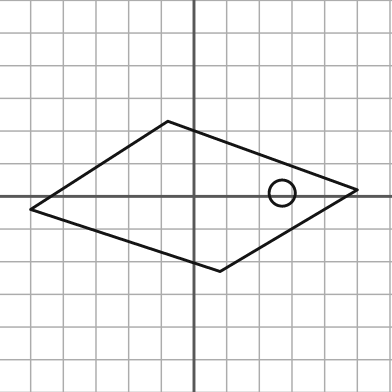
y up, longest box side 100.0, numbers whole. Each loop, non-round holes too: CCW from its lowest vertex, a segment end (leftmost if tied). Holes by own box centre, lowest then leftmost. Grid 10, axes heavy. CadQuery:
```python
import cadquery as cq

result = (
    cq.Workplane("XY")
    .moveTo(8.0, -23.0)
    .lineTo(50.0, 2.0)
    .lineTo(-8.0, 23.0)
    .lineTo(-50.0, -4.0)
    .close()
    .moveTo(27.0, 1.0)
    .circle(4.0)
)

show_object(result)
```